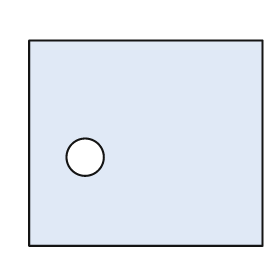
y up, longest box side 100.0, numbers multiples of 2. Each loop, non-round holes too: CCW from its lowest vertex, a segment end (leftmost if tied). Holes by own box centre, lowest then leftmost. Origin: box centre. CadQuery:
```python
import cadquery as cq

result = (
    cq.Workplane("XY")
    .moveTo(-50.0, -44.0)
    .lineTo(50.0, -44.0)
    .lineTo(50.0, 44.0)
    .lineTo(-50.0, 44.0)
    .close()
    .moveTo(-26.0, -6.0)
    .circle(8.0)
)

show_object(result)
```